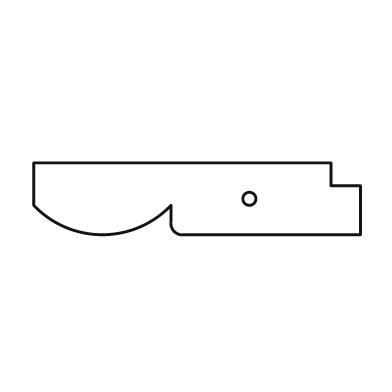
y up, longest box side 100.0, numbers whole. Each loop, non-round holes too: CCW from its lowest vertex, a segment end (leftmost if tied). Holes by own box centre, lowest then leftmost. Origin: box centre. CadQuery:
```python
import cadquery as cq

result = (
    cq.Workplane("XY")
    .moveTo(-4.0, -11.0)
    .lineTo(50.0, -11.0)
    .lineTo(50.0, 4.0)
    .lineTo(41.0, 4.0)
    .lineTo(41.0, 11.0)
    .lineTo(-50.0, 11.0)
    .lineTo(-50.0, -2.0)
    .threePointArc((-29.0, -11.0), (-8.0, -2.0))
    .lineTo(-8.0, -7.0)
    .threePointArc((-7.0, -10.0), (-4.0, -11.0))
    .close()
    .moveTo(16.0, 0.0)
    .circle(2.0)
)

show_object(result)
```